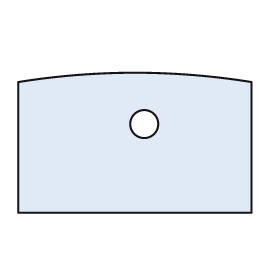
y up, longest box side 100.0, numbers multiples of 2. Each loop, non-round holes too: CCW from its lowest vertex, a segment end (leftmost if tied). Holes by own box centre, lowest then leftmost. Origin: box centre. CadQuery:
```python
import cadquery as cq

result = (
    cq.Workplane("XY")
    .moveTo(-50.0, -30.0)
    .lineTo(50.0, -30.0)
    .lineTo(50.0, 26.0)
    .threePointArc((0.0, 30.0), (-50.0, 26.0))
    .close()
    .moveTo(4.0, 8.0)
    .circle(6.0)
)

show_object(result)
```